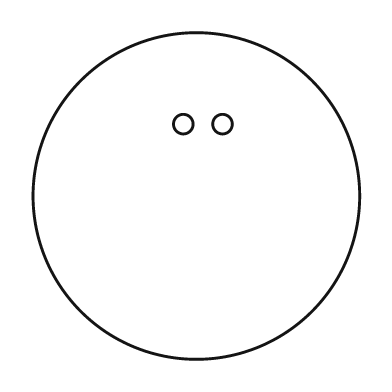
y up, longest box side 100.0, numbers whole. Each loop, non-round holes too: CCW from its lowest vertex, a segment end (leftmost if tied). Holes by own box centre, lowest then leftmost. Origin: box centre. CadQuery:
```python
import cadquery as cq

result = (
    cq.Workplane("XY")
    .moveTo(0.0, 0.0)
    .circle(50.0)
    .moveTo(-4.0, 22.0)
    .circle(3.0)
    .moveTo(8.0, 22.0)
    .circle(3.0)
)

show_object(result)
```